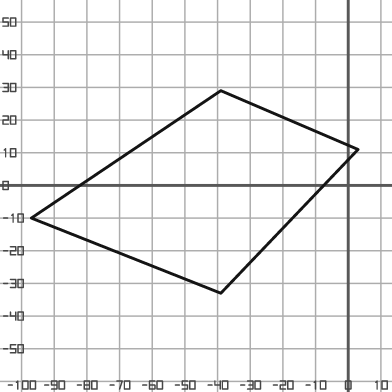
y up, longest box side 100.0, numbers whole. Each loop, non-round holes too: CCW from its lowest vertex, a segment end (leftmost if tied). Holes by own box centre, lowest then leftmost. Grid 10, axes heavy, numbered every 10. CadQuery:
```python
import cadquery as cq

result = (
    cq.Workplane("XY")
    .moveTo(-39.0, -33.0)
    .lineTo(3.0, 11.0)
    .lineTo(-39.0, 29.0)
    .lineTo(-97.0, -10.0)
    .close()
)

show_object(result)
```